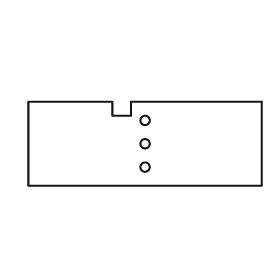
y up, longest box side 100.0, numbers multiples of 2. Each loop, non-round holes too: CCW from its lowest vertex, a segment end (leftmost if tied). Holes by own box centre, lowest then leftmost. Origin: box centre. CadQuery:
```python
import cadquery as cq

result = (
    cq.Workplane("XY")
    .moveTo(-50.0, -18.0)
    .lineTo(50.0, -18.0)
    .lineTo(50.0, 18.0)
    .lineTo(-6.0, 18.0)
    .lineTo(-6.0, 12.0)
    .lineTo(-14.0, 12.0)
    .lineTo(-14.0, 18.0)
    .lineTo(-50.0, 18.0)
    .close()
    .moveTo(0.0, -10.0)
    .circle(2.0)
    .moveTo(0.0, 0.0)
    .circle(2.0)
    .moveTo(0.0, 10.0)
    .circle(2.0)
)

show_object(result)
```